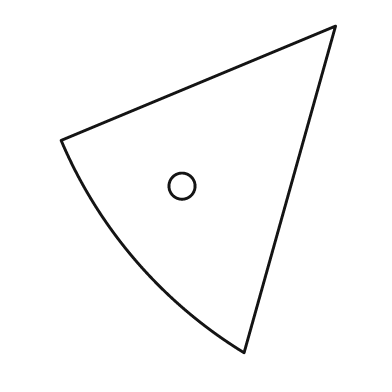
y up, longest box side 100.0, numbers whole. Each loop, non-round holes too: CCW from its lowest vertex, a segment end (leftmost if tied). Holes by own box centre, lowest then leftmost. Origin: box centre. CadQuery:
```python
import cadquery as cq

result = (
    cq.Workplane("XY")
    .moveTo(14.0, -50.0)
    .lineTo(42.0, 50.0)
    .lineTo(-42.0, 15.0)
    .threePointArc((-19.0, -22.0), (14.0, -50.0))
    .close()
    .moveTo(-5.0, 1.0)
    .circle(4.0)
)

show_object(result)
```